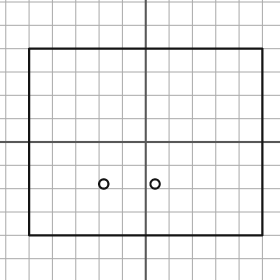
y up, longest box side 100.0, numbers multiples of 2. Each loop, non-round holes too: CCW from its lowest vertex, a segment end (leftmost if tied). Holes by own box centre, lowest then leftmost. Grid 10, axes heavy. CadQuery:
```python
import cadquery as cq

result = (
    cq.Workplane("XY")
    .moveTo(-50.0, -40.0)
    .lineTo(50.0, -40.0)
    .lineTo(50.0, 40.0)
    .lineTo(-50.0, 40.0)
    .close()
    .moveTo(-18.0, -18.0)
    .circle(2.0)
    .moveTo(4.0, -18.0)
    .circle(2.0)
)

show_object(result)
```